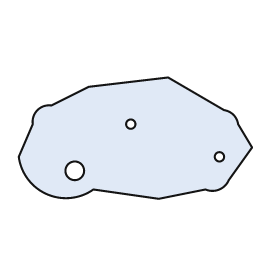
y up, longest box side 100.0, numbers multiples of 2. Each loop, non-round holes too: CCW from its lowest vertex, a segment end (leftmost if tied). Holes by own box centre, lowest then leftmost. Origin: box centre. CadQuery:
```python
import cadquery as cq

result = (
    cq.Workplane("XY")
    .moveTo(10.0, -26.0)
    .lineTo(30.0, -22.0)
    .threePointArc((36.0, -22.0), (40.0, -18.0))
    .lineTo(50.0, -4.0)
    .lineTo(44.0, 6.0)
    .threePointArc((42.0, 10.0), (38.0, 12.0))
    .lineTo(14.0, 26.0)
    .lineTo(-20.0, 22.0)
    .lineTo(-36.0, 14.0)
    .threePointArc((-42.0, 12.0), (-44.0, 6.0))
    .lineTo(-50.0, -8.0)
    .threePointArc((-38.0, -24.0), (-18.0, -22.0))
    .close()
    .moveTo(-26.0, -14.0)
    .circle(4.0)
    .moveTo(36.0, -8.0)
    .circle(2.0)
    .moveTo(-2.0, 6.0)
    .circle(2.0)
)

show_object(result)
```